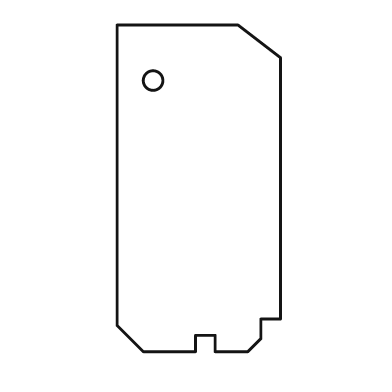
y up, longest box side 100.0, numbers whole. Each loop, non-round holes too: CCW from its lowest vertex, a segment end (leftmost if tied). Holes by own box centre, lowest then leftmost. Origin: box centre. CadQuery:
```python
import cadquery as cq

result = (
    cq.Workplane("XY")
    .moveTo(-17.0, -50.0)
    .lineTo(-1.0, -50.0)
    .lineTo(-1.0, -45.0)
    .lineTo(5.0, -45.0)
    .lineTo(5.0, -50.0)
    .lineTo(15.0, -50.0)
    .lineTo(19.0, -46.0)
    .lineTo(19.0, -40.0)
    .lineTo(25.0, -40.0)
    .lineTo(25.0, 40.0)
    .lineTo(12.0, 50.0)
    .lineTo(-25.0, 50.0)
    .lineTo(-25.0, -42.0)
    .close()
    .moveTo(-14.0, 33.0)
    .circle(3.0)
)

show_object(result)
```